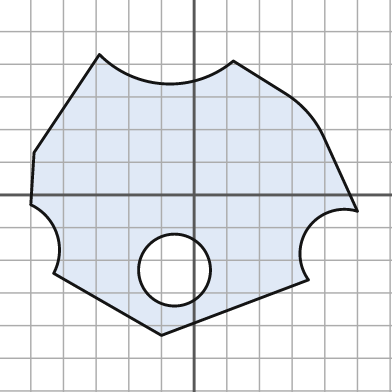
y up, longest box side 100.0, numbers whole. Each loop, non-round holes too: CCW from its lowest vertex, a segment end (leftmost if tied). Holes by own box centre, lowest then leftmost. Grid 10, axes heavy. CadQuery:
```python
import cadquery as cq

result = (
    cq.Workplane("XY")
    .moveTo(-10.0, -43.0)
    .lineTo(35.0, -26.0)
    .threePointArc((35.0, -10.0), (50.0, -5.0))
    .lineTo(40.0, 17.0)
    .threePointArc((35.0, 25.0), (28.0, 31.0))
    .lineTo(12.0, 41.0)
    .threePointArc((-9.0, 34.0), (-29.0, 43.0))
    .lineTo(-49.0, 13.0)
    .lineTo(-50.0, -3.0)
    .threePointArc((-42.0, -12.0), (-43.0, -24.0))
    .close()
    .moveTo(-6.0, -23.0)
    .circle(11.0)
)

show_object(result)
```